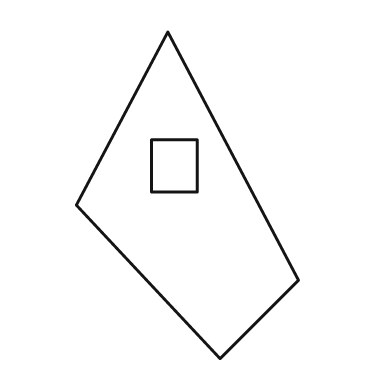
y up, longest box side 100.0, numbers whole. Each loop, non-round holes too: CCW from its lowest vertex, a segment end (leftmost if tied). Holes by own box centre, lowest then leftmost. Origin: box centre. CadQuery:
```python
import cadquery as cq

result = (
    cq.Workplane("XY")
    .moveTo(10.0, -50.0)
    .lineTo(34.0, -26.0)
    .lineTo(-6.0, 50.0)
    .lineTo(-34.0, -3.0)
    .close()
    .moveTo(-11.0, 1.0)
    .lineTo(3.0, 1.0)
    .lineTo(3.0, 17.0)
    .lineTo(-11.0, 17.0)
    .close()
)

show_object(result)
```